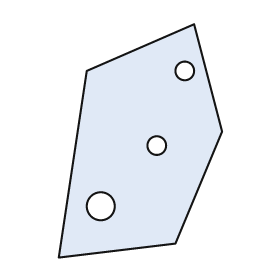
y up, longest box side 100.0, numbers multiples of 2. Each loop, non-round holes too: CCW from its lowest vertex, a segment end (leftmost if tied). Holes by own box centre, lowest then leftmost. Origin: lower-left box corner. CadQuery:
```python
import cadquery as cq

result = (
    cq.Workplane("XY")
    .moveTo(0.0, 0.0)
    .lineTo(50.0, 6.0)
    .lineTo(70.0, 54.0)
    .lineTo(58.0, 100.0)
    .lineTo(12.0, 80.0)
    .close()
    .moveTo(18.0, 22.0)
    .circle(6.0)
    .moveTo(42.0, 48.0)
    .circle(4.0)
    .moveTo(54.0, 80.0)
    .circle(4.0)
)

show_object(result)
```